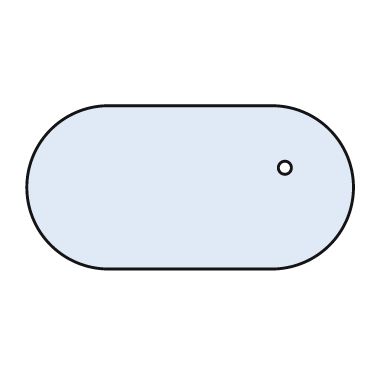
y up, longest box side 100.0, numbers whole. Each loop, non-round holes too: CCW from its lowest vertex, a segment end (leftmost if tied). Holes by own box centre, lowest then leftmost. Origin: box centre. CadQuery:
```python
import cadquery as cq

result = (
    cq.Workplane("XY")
    .moveTo(-25.0, -25.0)
    .lineTo(25.0, -25.0)
    .threePointArc((50.0, 0.0), (25.0, 25.0))
    .lineTo(-25.0, 25.0)
    .threePointArc((-50.0, 0.0), (-25.0, -25.0))
    .close()
    .moveTo(29.0, 6.0)
    .circle(2.0)
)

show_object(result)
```